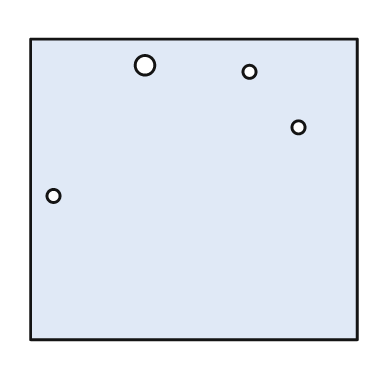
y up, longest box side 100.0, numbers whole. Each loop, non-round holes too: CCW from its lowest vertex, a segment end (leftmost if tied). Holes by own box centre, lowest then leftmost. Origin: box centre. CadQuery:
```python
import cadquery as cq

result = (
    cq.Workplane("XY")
    .moveTo(-50.0, -46.0)
    .lineTo(50.0, -46.0)
    .lineTo(50.0, 46.0)
    .lineTo(-50.0, 46.0)
    .close()
    .moveTo(-43.0, -2.0)
    .circle(2.0)
    .moveTo(32.0, 19.0)
    .circle(2.0)
    .moveTo(17.0, 36.0)
    .circle(2.0)
    .moveTo(-15.0, 38.0)
    .circle(3.0)
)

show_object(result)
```